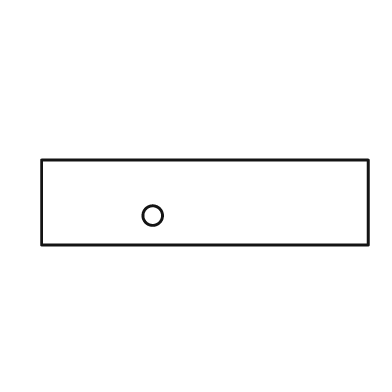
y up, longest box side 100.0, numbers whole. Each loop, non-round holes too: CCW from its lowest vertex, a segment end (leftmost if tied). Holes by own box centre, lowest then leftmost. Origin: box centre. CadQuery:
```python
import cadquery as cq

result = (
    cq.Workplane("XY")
    .moveTo(-50.0, -13.0)
    .lineTo(50.0, -13.0)
    .lineTo(50.0, 13.0)
    .lineTo(-50.0, 13.0)
    .close()
    .moveTo(-16.0, -4.0)
    .circle(3.0)
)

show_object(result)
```